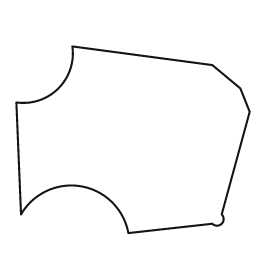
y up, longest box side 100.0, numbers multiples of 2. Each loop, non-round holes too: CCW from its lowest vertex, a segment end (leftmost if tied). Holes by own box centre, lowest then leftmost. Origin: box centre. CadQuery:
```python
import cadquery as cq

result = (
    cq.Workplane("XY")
    .moveTo(-2.0, -40.0)
    .lineTo(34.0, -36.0)
    .threePointArc((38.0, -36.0), (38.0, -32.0))
    .lineTo(50.0, 12.0)
    .lineTo(46.0, 22.0)
    .lineTo(34.0, 32.0)
    .lineTo(-26.0, 40.0)
    .threePointArc((-32.0, 22.0), (-50.0, 16.0))
    .lineTo(-48.0, -32.0)
    .threePointArc((-22.0, -20.0), (-2.0, -40.0))
    .close()
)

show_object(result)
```